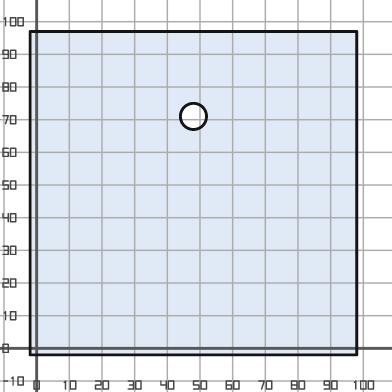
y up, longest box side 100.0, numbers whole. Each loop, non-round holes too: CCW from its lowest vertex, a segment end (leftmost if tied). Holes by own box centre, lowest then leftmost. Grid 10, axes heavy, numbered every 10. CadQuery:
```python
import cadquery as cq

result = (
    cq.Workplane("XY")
    .moveTo(-2.0, -2.0)
    .lineTo(98.0, -2.0)
    .lineTo(98.0, 97.0)
    .lineTo(-2.0, 97.0)
    .close()
    .moveTo(48.0, 71.0)
    .circle(4.0)
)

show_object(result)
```